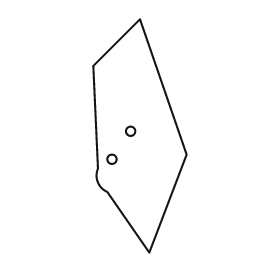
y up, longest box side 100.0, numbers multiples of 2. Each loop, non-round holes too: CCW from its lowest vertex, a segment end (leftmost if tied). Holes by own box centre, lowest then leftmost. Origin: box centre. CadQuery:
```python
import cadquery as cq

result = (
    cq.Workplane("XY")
    .moveTo(4.0, -50.0)
    .lineTo(20.0, -8.0)
    .lineTo(0.0, 50.0)
    .lineTo(-20.0, 30.0)
    .lineTo(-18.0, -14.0)
    .threePointArc((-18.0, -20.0), (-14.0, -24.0))
    .close()
    .moveTo(-12.0, -10.0)
    .circle(2.0)
    .moveTo(-4.0, 2.0)
    .circle(2.0)
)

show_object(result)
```